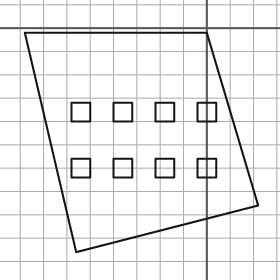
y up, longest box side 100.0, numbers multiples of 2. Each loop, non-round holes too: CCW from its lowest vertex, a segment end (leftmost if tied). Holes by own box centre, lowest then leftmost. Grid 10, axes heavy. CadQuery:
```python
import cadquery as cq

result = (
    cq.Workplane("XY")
    .moveTo(-56.0, -96.0)
    .lineTo(22.0, -76.0)
    .lineTo(0.0, -2.0)
    .lineTo(-78.0, -2.0)
    .close()
    .moveTo(-58.0, -64.0)
    .lineTo(-50.0, -64.0)
    .lineTo(-50.0, -56.0)
    .lineTo(-58.0, -56.0)
    .close()
    .moveTo(-40.0, -64.0)
    .lineTo(-32.0, -64.0)
    .lineTo(-32.0, -56.0)
    .lineTo(-40.0, -56.0)
    .close()
    .moveTo(-22.0, -64.0)
    .lineTo(-14.0, -64.0)
    .lineTo(-14.0, -56.0)
    .lineTo(-22.0, -56.0)
    .close()
    .moveTo(-4.0, -64.0)
    .lineTo(4.0, -64.0)
    .lineTo(4.0, -56.0)
    .lineTo(-4.0, -56.0)
    .close()
    .moveTo(-58.0, -40.0)
    .lineTo(-50.0, -40.0)
    .lineTo(-50.0, -32.0)
    .lineTo(-58.0, -32.0)
    .close()
    .moveTo(-40.0, -40.0)
    .lineTo(-32.0, -40.0)
    .lineTo(-32.0, -32.0)
    .lineTo(-40.0, -32.0)
    .close()
    .moveTo(-22.0, -40.0)
    .lineTo(-14.0, -40.0)
    .lineTo(-14.0, -32.0)
    .lineTo(-22.0, -32.0)
    .close()
    .moveTo(-4.0, -40.0)
    .lineTo(4.0, -40.0)
    .lineTo(4.0, -32.0)
    .lineTo(-4.0, -32.0)
    .close()
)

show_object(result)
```